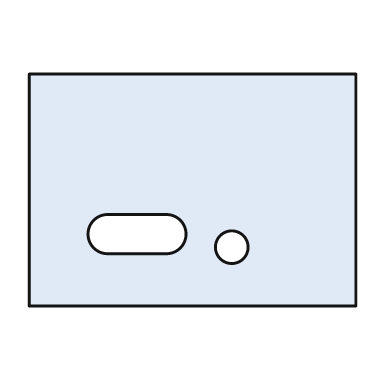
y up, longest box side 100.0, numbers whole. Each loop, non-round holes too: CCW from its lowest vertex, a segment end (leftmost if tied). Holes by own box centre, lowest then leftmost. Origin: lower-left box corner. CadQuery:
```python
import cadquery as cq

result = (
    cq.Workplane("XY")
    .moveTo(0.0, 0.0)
    .lineTo(100.0, 0.0)
    .lineTo(100.0, 71.0)
    .lineTo(0.0, 71.0)
    .close()
    .moveTo(62.0, 18.0)
    .circle(5.0)
    .moveTo(24.0, 16.0)
    .lineTo(42.0, 16.0)
    .threePointArc((48.0, 22.0), (42.0, 28.0))
    .lineTo(24.0, 28.0)
    .threePointArc((18.0, 22.0), (24.0, 16.0))
    .close()
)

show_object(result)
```